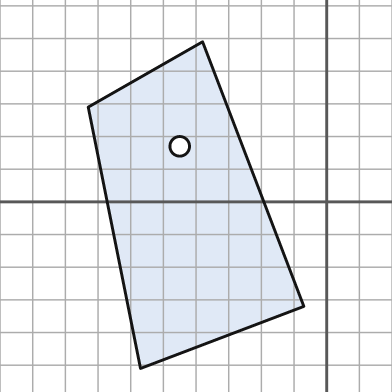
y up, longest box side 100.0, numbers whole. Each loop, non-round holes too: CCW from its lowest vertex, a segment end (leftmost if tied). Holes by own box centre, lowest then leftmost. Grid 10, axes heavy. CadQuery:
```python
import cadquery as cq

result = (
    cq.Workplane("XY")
    .moveTo(-57.0, -51.0)
    .lineTo(-7.0, -32.0)
    .lineTo(-38.0, 49.0)
    .lineTo(-73.0, 29.0)
    .close()
    .moveTo(-45.0, 17.0)
    .circle(3.0)
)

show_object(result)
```